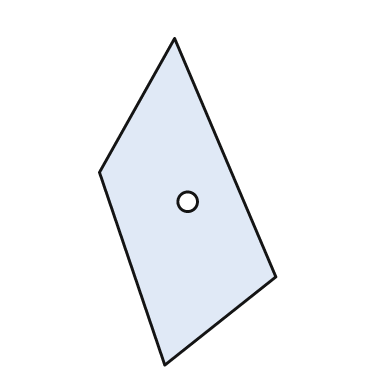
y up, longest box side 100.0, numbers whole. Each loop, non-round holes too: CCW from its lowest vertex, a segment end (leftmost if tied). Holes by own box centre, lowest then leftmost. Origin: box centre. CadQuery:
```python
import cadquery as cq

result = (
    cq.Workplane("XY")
    .moveTo(-7.0, -50.0)
    .lineTo(27.0, -23.0)
    .lineTo(-4.0, 50.0)
    .lineTo(-27.0, 9.0)
    .close()
    .moveTo(0.0, 0.0)
    .circle(3.0)
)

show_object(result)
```